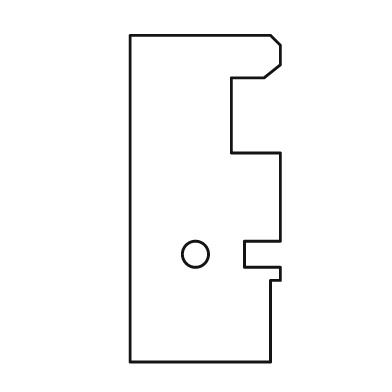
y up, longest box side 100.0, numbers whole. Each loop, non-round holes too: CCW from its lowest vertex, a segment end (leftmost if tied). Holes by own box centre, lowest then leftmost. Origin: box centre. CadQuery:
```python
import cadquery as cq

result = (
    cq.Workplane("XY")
    .moveTo(-23.0, -50.0)
    .lineTo(20.0, -50.0)
    .lineTo(20.0, -25.0)
    .lineTo(23.0, -25.0)
    .lineTo(23.0, -21.0)
    .lineTo(12.0, -21.0)
    .lineTo(12.0, -13.0)
    .lineTo(23.0, -13.0)
    .lineTo(23.0, 14.0)
    .lineTo(8.0, 14.0)
    .lineTo(8.0, 37.0)
    .lineTo(18.0, 37.0)
    .lineTo(23.0, 41.0)
    .lineTo(23.0, 47.0)
    .lineTo(20.0, 50.0)
    .lineTo(-23.0, 50.0)
    .close()
    .moveTo(-3.0, -17.0)
    .circle(4.0)
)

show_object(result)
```